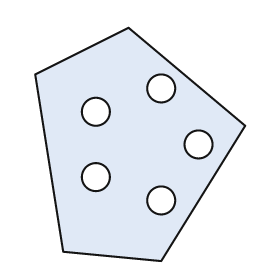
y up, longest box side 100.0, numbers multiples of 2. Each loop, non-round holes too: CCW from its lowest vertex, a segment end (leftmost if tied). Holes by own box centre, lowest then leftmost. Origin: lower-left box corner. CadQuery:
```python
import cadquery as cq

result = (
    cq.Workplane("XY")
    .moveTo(54.0, 0.0)
    .lineTo(90.0, 58.0)
    .lineTo(40.0, 100.0)
    .lineTo(0.0, 80.0)
    .lineTo(12.0, 4.0)
    .close()
    .moveTo(54.0, 26.0)
    .circle(6.0)
    .moveTo(26.0, 36.0)
    .circle(6.0)
    .moveTo(70.0, 50.0)
    .circle(6.0)
    .moveTo(26.0, 64.0)
    .circle(6.0)
    .moveTo(54.0, 74.0)
    .circle(6.0)
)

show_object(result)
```